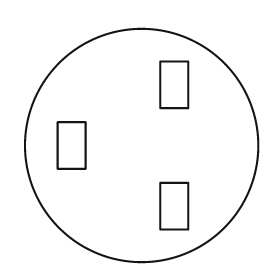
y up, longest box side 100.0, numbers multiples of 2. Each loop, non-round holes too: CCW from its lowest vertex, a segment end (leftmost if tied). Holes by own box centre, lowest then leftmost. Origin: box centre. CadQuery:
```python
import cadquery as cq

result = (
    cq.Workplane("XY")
    .moveTo(0.0, 0.0)
    .circle(50.0)
    .moveTo(8.0, -36.0)
    .lineTo(20.0, -36.0)
    .lineTo(20.0, -16.0)
    .lineTo(8.0, -16.0)
    .close()
    .moveTo(-36.0, -10.0)
    .lineTo(-24.0, -10.0)
    .lineTo(-24.0, 10.0)
    .lineTo(-36.0, 10.0)
    .close()
    .moveTo(8.0, 16.0)
    .lineTo(20.0, 16.0)
    .lineTo(20.0, 36.0)
    .lineTo(8.0, 36.0)
    .close()
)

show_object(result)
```